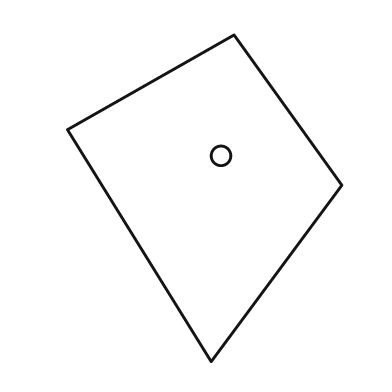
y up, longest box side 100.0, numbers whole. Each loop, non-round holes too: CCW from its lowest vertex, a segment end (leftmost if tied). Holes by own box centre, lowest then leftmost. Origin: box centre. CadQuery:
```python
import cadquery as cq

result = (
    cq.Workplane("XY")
    .moveTo(2.0, -50.0)
    .lineTo(42.0, 4.0)
    .lineTo(9.0, 50.0)
    .lineTo(-42.0, 21.0)
    .close()
    .moveTo(5.0, 13.0)
    .circle(3.0)
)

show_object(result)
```